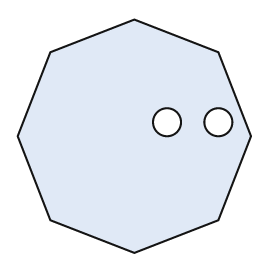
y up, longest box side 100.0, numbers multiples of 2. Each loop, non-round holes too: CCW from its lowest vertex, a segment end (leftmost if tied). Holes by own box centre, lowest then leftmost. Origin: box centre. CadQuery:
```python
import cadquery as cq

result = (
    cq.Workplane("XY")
    .moveTo(0.0, -50.0)
    .lineTo(36.0, -36.0)
    .lineTo(50.0, 0.0)
    .lineTo(36.0, 36.0)
    .lineTo(0.0, 50.0)
    .lineTo(-36.0, 36.0)
    .lineTo(-50.0, 0.0)
    .lineTo(-36.0, -36.0)
    .close()
    .moveTo(14.0, 6.0)
    .circle(6.0)
    .moveTo(36.0, 6.0)
    .circle(6.0)
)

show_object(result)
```